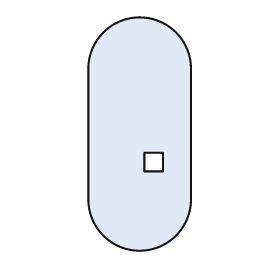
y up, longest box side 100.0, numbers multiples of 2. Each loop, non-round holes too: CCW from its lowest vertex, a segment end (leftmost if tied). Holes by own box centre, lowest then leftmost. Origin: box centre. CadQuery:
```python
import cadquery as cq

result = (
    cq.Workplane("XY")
    .moveTo(-22.0, -28.0)
    .threePointArc((0.0, -50.0), (22.0, -28.0))
    .lineTo(22.0, 28.0)
    .threePointArc((0.0, 50.0), (-22.0, 28.0))
    .close()
    .moveTo(2.0, -16.0)
    .lineTo(10.0, -16.0)
    .lineTo(10.0, -8.0)
    .lineTo(2.0, -8.0)
    .close()
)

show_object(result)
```